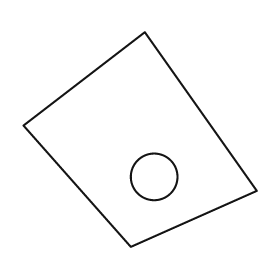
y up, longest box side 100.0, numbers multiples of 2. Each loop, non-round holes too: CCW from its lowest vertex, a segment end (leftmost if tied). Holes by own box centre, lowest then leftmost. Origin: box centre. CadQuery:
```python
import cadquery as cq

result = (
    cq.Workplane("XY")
    .moveTo(-4.0, -46.0)
    .lineTo(50.0, -22.0)
    .lineTo(2.0, 46.0)
    .lineTo(-50.0, 6.0)
    .close()
    .moveTo(6.0, -16.0)
    .circle(10.0)
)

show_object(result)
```